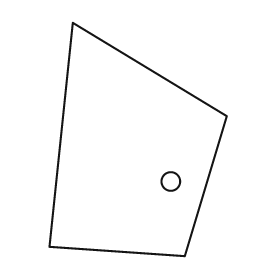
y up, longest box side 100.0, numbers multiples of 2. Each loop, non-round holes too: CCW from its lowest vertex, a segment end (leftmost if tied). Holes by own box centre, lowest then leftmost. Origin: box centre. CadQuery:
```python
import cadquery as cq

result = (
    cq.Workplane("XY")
    .moveTo(20.0, -50.0)
    .lineTo(38.0, 10.0)
    .lineTo(-28.0, 50.0)
    .lineTo(-38.0, -46.0)
    .close()
    .moveTo(14.0, -18.0)
    .circle(4.0)
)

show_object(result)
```